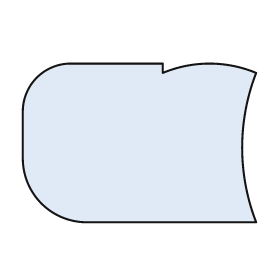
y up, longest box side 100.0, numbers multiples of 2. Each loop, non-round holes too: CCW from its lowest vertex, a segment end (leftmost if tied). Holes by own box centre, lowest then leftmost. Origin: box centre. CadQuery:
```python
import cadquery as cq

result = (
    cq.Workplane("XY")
    .moveTo(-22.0, -34.0)
    .lineTo(50.0, -34.0)
    .threePointArc((44.0, -2.0), (50.0, 30.0))
    .threePointArc((30.0, 34.0), (10.0, 30.0))
    .lineTo(10.0, 34.0)
    .lineTo(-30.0, 34.0)
    .threePointArc((-44.0, 28.0), (-50.0, 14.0))
    .lineTo(-50.0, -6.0)
    .threePointArc((-42.0, -26.0), (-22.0, -34.0))
    .close()
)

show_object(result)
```